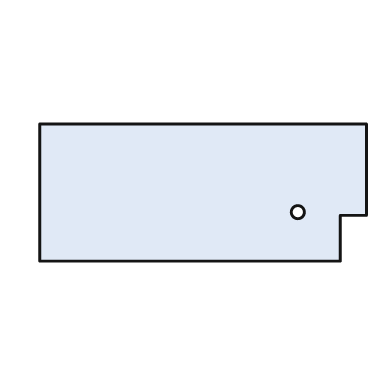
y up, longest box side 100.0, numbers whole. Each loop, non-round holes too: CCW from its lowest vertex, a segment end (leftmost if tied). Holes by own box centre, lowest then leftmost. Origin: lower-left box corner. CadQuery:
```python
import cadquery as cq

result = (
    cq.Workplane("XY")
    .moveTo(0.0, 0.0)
    .lineTo(92.0, 0.0)
    .lineTo(92.0, 14.0)
    .lineTo(100.0, 14.0)
    .lineTo(100.0, 42.0)
    .lineTo(0.0, 42.0)
    .close()
    .moveTo(79.0, 15.0)
    .circle(2.0)
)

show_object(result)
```